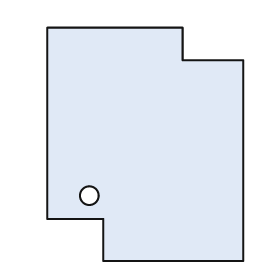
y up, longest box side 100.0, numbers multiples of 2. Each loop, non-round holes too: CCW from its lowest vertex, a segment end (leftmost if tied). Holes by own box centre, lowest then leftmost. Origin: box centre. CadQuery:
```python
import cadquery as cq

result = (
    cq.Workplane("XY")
    .moveTo(-18.0, -50.0)
    .lineTo(42.0, -50.0)
    .lineTo(42.0, 36.0)
    .lineTo(16.0, 36.0)
    .lineTo(16.0, 50.0)
    .lineTo(-42.0, 50.0)
    .lineTo(-42.0, -32.0)
    .lineTo(-18.0, -32.0)
    .close()
    .moveTo(-24.0, -22.0)
    .circle(4.0)
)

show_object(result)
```